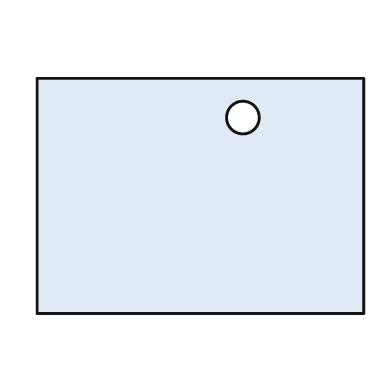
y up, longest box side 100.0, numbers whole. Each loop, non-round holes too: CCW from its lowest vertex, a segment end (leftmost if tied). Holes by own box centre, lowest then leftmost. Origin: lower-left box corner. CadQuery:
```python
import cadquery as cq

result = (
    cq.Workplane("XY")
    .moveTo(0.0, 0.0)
    .lineTo(100.0, 0.0)
    .lineTo(100.0, 72.0)
    .lineTo(0.0, 72.0)
    .close()
    .moveTo(63.0, 60.0)
    .circle(5.0)
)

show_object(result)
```